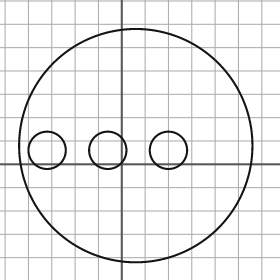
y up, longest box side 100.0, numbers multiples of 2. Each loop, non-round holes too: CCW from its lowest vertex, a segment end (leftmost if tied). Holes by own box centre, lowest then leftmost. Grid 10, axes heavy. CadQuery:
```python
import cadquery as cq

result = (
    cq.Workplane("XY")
    .moveTo(6.0, 8.0)
    .circle(50.0)
    .moveTo(-32.0, 6.0)
    .circle(8.0)
    .moveTo(-6.0, 6.0)
    .circle(8.0)
    .moveTo(20.0, 6.0)
    .circle(8.0)
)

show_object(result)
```